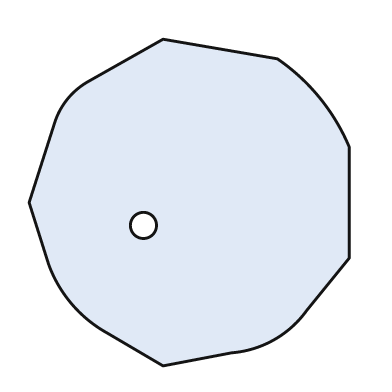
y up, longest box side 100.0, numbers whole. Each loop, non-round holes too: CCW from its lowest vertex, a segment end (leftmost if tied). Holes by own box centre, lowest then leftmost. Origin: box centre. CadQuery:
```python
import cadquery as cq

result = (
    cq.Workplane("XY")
    .moveTo(-8.0, -50.0)
    .lineTo(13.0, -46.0)
    .threePointArc((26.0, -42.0), (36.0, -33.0))
    .lineTo(49.0, -17.0)
    .lineTo(49.0, 17.0)
    .threePointArc((40.0, 32.0), (27.0, 44.0))
    .lineTo(-8.0, 50.0)
    .lineTo(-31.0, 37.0)
    .threePointArc((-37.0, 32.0), (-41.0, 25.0))
    .lineTo(-49.0, 0.0)
    .lineTo(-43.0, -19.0)
    .threePointArc((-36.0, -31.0), (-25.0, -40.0))
    .close()
    .moveTo(-14.0, -7.0)
    .circle(4.0)
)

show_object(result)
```